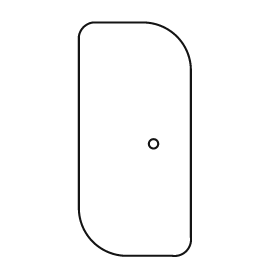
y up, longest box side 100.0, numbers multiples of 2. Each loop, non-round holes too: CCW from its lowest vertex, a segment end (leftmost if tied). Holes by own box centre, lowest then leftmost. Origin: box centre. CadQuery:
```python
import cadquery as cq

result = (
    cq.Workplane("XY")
    .moveTo(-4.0, -50.0)
    .lineTo(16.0, -50.0)
    .threePointArc((22.0, -48.0), (24.0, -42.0))
    .lineTo(24.0, 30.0)
    .threePointArc((18.0, 44.0), (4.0, 50.0))
    .lineTo(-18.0, 50.0)
    .threePointArc((-22.0, 48.0), (-24.0, 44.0))
    .lineTo(-24.0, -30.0)
    .threePointArc((-18.0, -44.0), (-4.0, -50.0))
    .close()
    .moveTo(8.0, -2.0)
    .circle(2.0)
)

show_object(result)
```